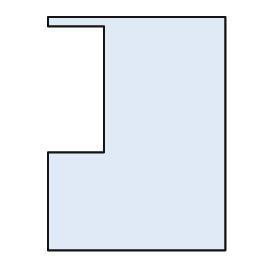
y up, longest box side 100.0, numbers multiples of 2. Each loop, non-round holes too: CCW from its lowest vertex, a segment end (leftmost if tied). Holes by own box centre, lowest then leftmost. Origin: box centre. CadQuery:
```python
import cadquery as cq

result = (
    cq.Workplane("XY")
    .moveTo(-38.0, -50.0)
    .lineTo(38.0, -50.0)
    .lineTo(38.0, 50.0)
    .lineTo(-38.0, 50.0)
    .lineTo(-38.0, 46.0)
    .lineTo(-14.0, 46.0)
    .lineTo(-14.0, -8.0)
    .lineTo(-38.0, -8.0)
    .close()
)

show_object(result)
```